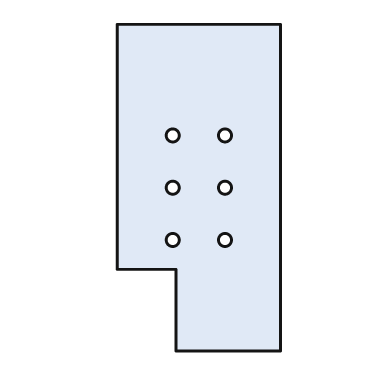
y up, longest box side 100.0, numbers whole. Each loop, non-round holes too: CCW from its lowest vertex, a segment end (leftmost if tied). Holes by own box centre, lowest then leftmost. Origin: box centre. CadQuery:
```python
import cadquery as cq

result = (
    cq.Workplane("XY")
    .moveTo(-7.0, -50.0)
    .lineTo(25.0, -50.0)
    .lineTo(25.0, 50.0)
    .lineTo(-25.0, 50.0)
    .lineTo(-25.0, -25.0)
    .lineTo(-7.0, -25.0)
    .close()
    .moveTo(-8.0, -16.0)
    .circle(2.0)
    .moveTo(8.0, -16.0)
    .circle(2.0)
    .moveTo(-8.0, 0.0)
    .circle(2.0)
    .moveTo(8.0, 0.0)
    .circle(2.0)
    .moveTo(-8.0, 16.0)
    .circle(2.0)
    .moveTo(8.0, 16.0)
    .circle(2.0)
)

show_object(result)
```